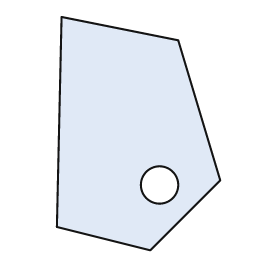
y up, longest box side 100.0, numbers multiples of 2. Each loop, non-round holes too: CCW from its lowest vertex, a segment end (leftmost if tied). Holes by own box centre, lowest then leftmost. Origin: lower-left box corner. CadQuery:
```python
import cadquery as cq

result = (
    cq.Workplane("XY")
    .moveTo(40.0, 0.0)
    .lineTo(70.0, 30.0)
    .lineTo(52.0, 90.0)
    .lineTo(2.0, 100.0)
    .lineTo(0.0, 10.0)
    .close()
    .moveTo(44.0, 28.0)
    .circle(8.0)
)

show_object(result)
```